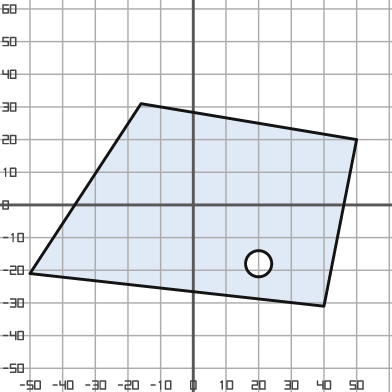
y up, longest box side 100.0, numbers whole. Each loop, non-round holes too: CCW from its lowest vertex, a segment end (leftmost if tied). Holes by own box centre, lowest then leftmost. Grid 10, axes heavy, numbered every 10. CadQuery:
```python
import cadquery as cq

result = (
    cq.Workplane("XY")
    .moveTo(40.0, -31.0)
    .lineTo(50.0, 20.0)
    .lineTo(-16.0, 31.0)
    .lineTo(-50.0, -21.0)
    .close()
    .moveTo(20.0, -18.0)
    .circle(4.0)
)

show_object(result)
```